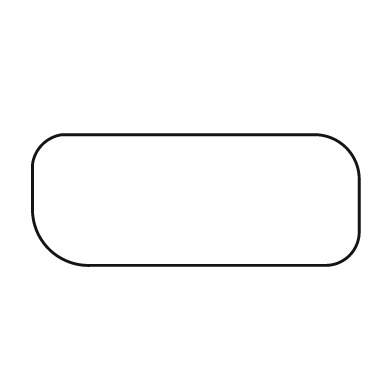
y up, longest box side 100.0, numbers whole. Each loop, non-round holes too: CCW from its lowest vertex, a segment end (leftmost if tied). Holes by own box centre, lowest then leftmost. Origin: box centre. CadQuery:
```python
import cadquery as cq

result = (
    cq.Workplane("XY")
    .moveTo(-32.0, -20.0)
    .lineTo(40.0, -20.0)
    .threePointArc((47.0, -17.0), (50.0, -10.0))
    .lineTo(50.0, 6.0)
    .threePointArc((46.0, 16.0), (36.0, 20.0))
    .lineTo(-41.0, 20.0)
    .threePointArc((-47.0, 17.0), (-50.0, 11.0))
    .lineTo(-50.0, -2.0)
    .threePointArc((-45.0, -15.0), (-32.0, -20.0))
    .close()
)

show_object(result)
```